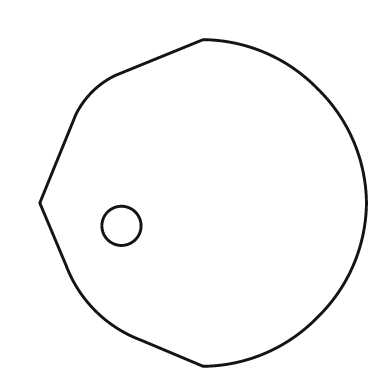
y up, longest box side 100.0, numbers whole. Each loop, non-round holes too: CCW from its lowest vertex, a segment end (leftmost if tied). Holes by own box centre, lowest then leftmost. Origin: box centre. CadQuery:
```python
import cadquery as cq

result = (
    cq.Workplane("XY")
    .moveTo(0.0, -50.0)
    .threePointArc((19.0, -46.0), (35.0, -35.0))
    .threePointArc((46.0, -19.0), (50.0, 0.0))
    .threePointArc((46.0, 19.0), (35.0, 35.0))
    .threePointArc((19.0, 46.0), (0.0, 50.0))
    .lineTo(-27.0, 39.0)
    .threePointArc((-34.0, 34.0), (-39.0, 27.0))
    .lineTo(-50.0, 0.0)
    .lineTo(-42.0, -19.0)
    .threePointArc((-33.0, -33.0), (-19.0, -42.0))
    .close()
    .moveTo(-25.0, -7.0)
    .circle(6.0)
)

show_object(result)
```